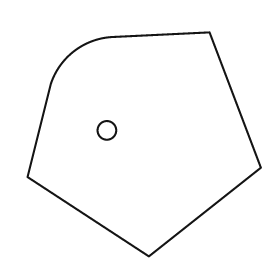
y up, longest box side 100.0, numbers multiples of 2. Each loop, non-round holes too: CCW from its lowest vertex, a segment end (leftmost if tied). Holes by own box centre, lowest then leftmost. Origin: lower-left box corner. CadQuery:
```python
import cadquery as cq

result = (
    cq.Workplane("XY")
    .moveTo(52.0, 0.0)
    .lineTo(100.0, 38.0)
    .lineTo(78.0, 96.0)
    .lineTo(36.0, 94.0)
    .threePointArc((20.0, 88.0), (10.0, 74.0))
    .lineTo(0.0, 34.0)
    .close()
    .moveTo(34.0, 54.0)
    .circle(4.0)
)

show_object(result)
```